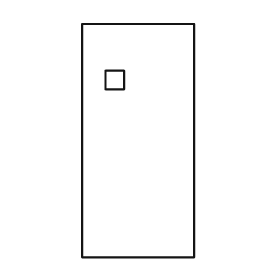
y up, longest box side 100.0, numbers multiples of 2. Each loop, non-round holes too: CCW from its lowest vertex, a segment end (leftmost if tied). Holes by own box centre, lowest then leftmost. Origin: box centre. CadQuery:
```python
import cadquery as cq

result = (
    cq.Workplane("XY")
    .moveTo(-24.0, -50.0)
    .lineTo(24.0, -50.0)
    .lineTo(24.0, 50.0)
    .lineTo(-24.0, 50.0)
    .close()
    .moveTo(-14.0, 22.0)
    .lineTo(-6.0, 22.0)
    .lineTo(-6.0, 30.0)
    .lineTo(-14.0, 30.0)
    .close()
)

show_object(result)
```